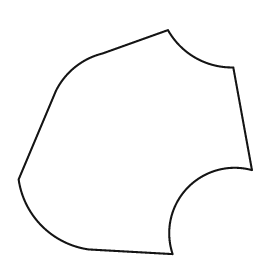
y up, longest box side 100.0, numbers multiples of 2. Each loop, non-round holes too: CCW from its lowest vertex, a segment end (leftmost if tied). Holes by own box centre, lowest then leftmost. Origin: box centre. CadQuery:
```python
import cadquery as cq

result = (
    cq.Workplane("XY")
    .moveTo(16.0, -48.0)
    .threePointArc((22.0, -20.0), (50.0, -12.0))
    .lineTo(42.0, 32.0)
    .threePointArc((26.0, 36.0), (14.0, 48.0))
    .lineTo(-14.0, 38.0)
    .threePointArc((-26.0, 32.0), (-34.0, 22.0))
    .lineTo(-50.0, -16.0)
    .threePointArc((-40.0, -36.0), (-20.0, -46.0))
    .close()
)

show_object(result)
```